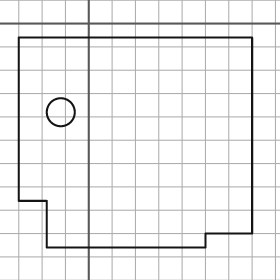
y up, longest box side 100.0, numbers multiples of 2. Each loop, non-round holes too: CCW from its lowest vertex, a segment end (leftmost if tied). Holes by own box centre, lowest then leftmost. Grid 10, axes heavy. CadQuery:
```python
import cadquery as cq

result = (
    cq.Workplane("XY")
    .moveTo(-18.0, -96.0)
    .lineTo(50.0, -96.0)
    .lineTo(50.0, -90.0)
    .lineTo(70.0, -90.0)
    .lineTo(70.0, -6.0)
    .lineTo(-30.0, -6.0)
    .lineTo(-30.0, -76.0)
    .lineTo(-18.0, -76.0)
    .close()
    .moveTo(-12.0, -38.0)
    .circle(6.0)
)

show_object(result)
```